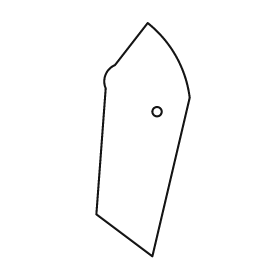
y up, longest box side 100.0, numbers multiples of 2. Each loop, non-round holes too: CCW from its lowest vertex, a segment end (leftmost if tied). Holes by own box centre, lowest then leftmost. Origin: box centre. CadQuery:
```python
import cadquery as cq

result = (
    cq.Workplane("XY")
    .moveTo(4.0, -50.0)
    .lineTo(20.0, 18.0)
    .threePointArc((14.0, 36.0), (2.0, 50.0))
    .lineTo(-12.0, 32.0)
    .threePointArc((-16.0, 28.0), (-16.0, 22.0))
    .lineTo(-20.0, -32.0)
    .close()
    .moveTo(6.0, 12.0)
    .circle(2.0)
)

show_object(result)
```